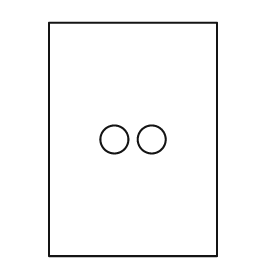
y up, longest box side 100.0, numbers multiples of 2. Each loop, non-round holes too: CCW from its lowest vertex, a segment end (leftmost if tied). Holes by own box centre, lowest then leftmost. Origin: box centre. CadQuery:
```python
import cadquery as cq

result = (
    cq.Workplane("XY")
    .moveTo(-36.0, -50.0)
    .lineTo(36.0, -50.0)
    .lineTo(36.0, 50.0)
    .lineTo(-36.0, 50.0)
    .close()
    .moveTo(-8.0, 0.0)
    .circle(6.0)
    .moveTo(8.0, 0.0)
    .circle(6.0)
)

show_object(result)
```